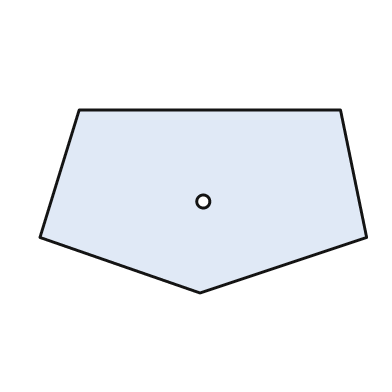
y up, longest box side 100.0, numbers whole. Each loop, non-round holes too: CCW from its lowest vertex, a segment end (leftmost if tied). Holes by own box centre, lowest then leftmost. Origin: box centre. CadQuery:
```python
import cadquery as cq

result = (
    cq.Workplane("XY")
    .moveTo(-1.0, -28.0)
    .lineTo(50.0, -11.0)
    .lineTo(42.0, 28.0)
    .lineTo(-38.0, 28.0)
    .lineTo(-50.0, -11.0)
    .close()
    .moveTo(0.0, 0.0)
    .circle(2.0)
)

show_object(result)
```